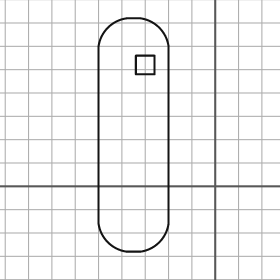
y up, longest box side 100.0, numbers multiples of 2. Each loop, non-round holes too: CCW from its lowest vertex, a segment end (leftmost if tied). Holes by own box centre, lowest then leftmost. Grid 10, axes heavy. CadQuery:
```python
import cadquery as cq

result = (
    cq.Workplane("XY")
    .moveTo(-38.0, -28.0)
    .lineTo(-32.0, -28.0)
    .threePointArc((-24.0, -24.0), (-20.0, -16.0))
    .lineTo(-20.0, 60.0)
    .threePointArc((-24.0, 68.0), (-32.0, 72.0))
    .lineTo(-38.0, 72.0)
    .threePointArc((-46.0, 68.0), (-50.0, 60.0))
    .lineTo(-50.0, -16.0)
    .threePointArc((-46.0, -24.0), (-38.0, -28.0))
    .close()
    .moveTo(-34.0, 48.0)
    .lineTo(-26.0, 48.0)
    .lineTo(-26.0, 56.0)
    .lineTo(-34.0, 56.0)
    .close()
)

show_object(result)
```